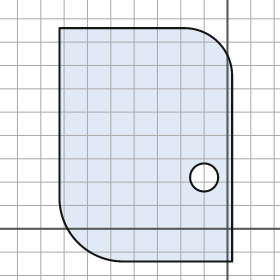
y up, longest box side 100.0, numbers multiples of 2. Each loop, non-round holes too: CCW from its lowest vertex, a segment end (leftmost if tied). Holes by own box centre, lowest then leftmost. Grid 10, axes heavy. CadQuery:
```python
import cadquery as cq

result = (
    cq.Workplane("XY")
    .moveTo(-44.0, -14.0)
    .lineTo(2.0, -14.0)
    .lineTo(2.0, 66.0)
    .threePointArc((-4.0, 80.0), (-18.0, 86.0))
    .lineTo(-72.0, 86.0)
    .lineTo(-72.0, 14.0)
    .threePointArc((-64.0, -6.0), (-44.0, -14.0))
    .close()
    .moveTo(-10.0, 22.0)
    .circle(6.0)
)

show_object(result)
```